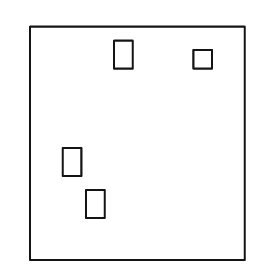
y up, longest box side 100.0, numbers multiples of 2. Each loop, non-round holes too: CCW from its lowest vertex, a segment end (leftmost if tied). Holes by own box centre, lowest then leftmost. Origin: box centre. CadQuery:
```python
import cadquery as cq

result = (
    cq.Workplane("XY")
    .moveTo(-46.0, -50.0)
    .lineTo(46.0, -50.0)
    .lineTo(46.0, 50.0)
    .lineTo(-46.0, 50.0)
    .close()
    .moveTo(-22.0, -32.0)
    .lineTo(-14.0, -32.0)
    .lineTo(-14.0, -20.0)
    .lineTo(-22.0, -20.0)
    .close()
    .moveTo(-32.0, -14.0)
    .lineTo(-24.0, -14.0)
    .lineTo(-24.0, -2.0)
    .lineTo(-32.0, -2.0)
    .close()
    .moveTo(24.0, 32.0)
    .lineTo(32.0, 32.0)
    .lineTo(32.0, 40.0)
    .lineTo(24.0, 40.0)
    .close()
    .moveTo(-10.0, 32.0)
    .lineTo(-2.0, 32.0)
    .lineTo(-2.0, 44.0)
    .lineTo(-10.0, 44.0)
    .close()
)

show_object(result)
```